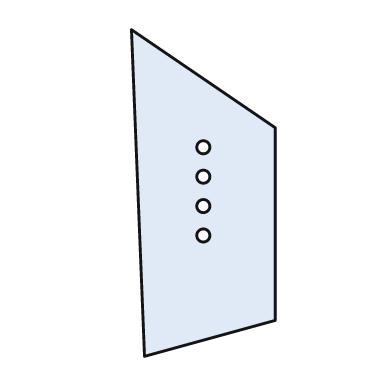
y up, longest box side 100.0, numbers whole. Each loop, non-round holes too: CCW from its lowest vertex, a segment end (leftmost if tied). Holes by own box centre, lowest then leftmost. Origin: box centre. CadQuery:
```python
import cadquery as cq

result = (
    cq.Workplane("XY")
    .moveTo(-18.0, -50.0)
    .lineTo(22.0, -39.0)
    .lineTo(22.0, 20.0)
    .lineTo(-22.0, 50.0)
    .close()
    .moveTo(0.0, -13.0)
    .circle(2.0)
    .moveTo(0.0, -4.0)
    .circle(2.0)
    .moveTo(0.0, 5.0)
    .circle(2.0)
    .moveTo(0.0, 14.0)
    .circle(2.0)
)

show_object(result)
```